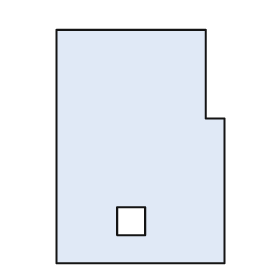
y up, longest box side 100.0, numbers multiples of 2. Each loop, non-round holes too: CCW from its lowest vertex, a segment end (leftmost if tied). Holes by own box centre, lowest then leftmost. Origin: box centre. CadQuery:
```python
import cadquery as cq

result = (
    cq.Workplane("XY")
    .moveTo(-36.0, -50.0)
    .lineTo(36.0, -50.0)
    .lineTo(36.0, 12.0)
    .lineTo(28.0, 12.0)
    .lineTo(28.0, 50.0)
    .lineTo(-36.0, 50.0)
    .close()
    .moveTo(-10.0, -38.0)
    .lineTo(2.0, -38.0)
    .lineTo(2.0, -26.0)
    .lineTo(-10.0, -26.0)
    .close()
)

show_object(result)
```